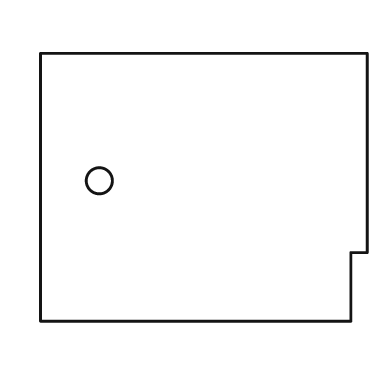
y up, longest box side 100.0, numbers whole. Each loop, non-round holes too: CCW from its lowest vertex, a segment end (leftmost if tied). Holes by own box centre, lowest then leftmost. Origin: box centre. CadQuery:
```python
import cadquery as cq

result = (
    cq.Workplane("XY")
    .moveTo(-50.0, -41.0)
    .lineTo(45.0, -41.0)
    .lineTo(45.0, -20.0)
    .lineTo(50.0, -20.0)
    .lineTo(50.0, 41.0)
    .lineTo(-50.0, 41.0)
    .close()
    .moveTo(-32.0, 2.0)
    .circle(4.0)
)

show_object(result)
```